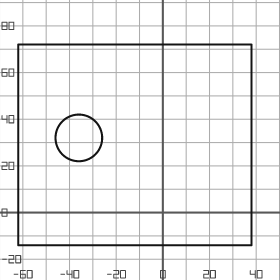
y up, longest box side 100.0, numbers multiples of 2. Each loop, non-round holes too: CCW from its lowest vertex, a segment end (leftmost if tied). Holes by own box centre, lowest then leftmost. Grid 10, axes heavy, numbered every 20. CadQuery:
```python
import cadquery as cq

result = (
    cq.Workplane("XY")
    .moveTo(-62.0, -14.0)
    .lineTo(38.0, -14.0)
    .lineTo(38.0, 72.0)
    .lineTo(-62.0, 72.0)
    .close()
    .moveTo(-36.0, 32.0)
    .circle(10.0)
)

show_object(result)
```